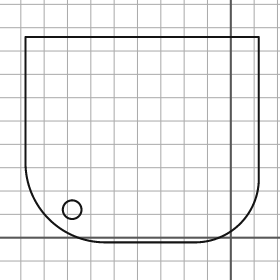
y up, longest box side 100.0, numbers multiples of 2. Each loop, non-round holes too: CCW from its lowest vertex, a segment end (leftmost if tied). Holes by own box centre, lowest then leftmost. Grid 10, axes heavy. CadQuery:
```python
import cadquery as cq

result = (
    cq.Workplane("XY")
    .moveTo(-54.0, -2.0)
    .lineTo(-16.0, -2.0)
    .threePointArc((4.0, 6.0), (12.0, 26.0))
    .lineTo(12.0, 86.0)
    .lineTo(-88.0, 86.0)
    .lineTo(-88.0, 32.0)
    .threePointArc((-78.0, 8.0), (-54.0, -2.0))
    .close()
    .moveTo(-68.0, 12.0)
    .circle(4.0)
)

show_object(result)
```